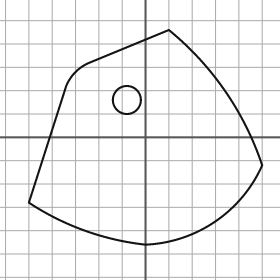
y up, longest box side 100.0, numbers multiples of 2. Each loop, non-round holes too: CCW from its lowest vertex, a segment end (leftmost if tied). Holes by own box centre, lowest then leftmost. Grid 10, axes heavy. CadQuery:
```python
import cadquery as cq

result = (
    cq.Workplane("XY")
    .moveTo(0.0, -46.0)
    .threePointArc((30.0, -36.0), (50.0, -12.0))
    .threePointArc((34.0, 20.0), (10.0, 46.0))
    .lineTo(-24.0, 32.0)
    .threePointArc((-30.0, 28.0), (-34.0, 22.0))
    .lineTo(-50.0, -28.0)
    .threePointArc((-26.0, -40.0), (0.0, -46.0))
    .close()
    .moveTo(-8.0, 16.0)
    .circle(6.0)
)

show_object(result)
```